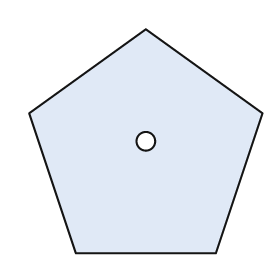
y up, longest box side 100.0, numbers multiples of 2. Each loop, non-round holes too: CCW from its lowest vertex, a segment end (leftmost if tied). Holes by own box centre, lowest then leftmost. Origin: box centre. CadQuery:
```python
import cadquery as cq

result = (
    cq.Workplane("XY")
    .moveTo(-30.0, -48.0)
    .lineTo(30.0, -48.0)
    .lineTo(50.0, 12.0)
    .lineTo(0.0, 48.0)
    .lineTo(-50.0, 12.0)
    .close()
    .moveTo(0.0, 0.0)
    .circle(4.0)
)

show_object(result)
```